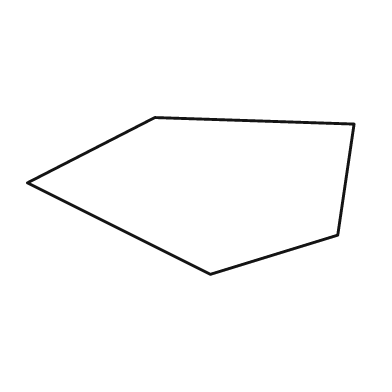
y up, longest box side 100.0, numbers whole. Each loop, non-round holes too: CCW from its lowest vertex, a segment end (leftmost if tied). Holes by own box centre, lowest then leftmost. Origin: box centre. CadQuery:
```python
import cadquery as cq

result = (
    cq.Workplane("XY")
    .moveTo(6.0, -24.0)
    .lineTo(45.0, -12.0)
    .lineTo(50.0, 22.0)
    .lineTo(-11.0, 24.0)
    .lineTo(-50.0, 4.0)
    .close()
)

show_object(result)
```